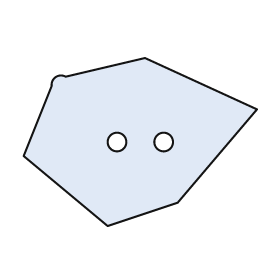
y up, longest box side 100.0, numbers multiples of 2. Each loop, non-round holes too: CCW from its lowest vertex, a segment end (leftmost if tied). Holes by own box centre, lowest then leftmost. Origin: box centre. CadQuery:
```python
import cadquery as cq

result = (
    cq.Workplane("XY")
    .moveTo(-14.0, -36.0)
    .lineTo(16.0, -26.0)
    .lineTo(50.0, 14.0)
    .lineTo(2.0, 36.0)
    .lineTo(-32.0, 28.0)
    .threePointArc((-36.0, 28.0), (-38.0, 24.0))
    .lineTo(-50.0, -6.0)
    .close()
    .moveTo(-10.0, 0.0)
    .circle(4.0)
    .moveTo(10.0, 0.0)
    .circle(4.0)
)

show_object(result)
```